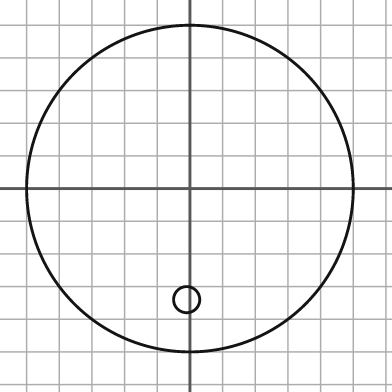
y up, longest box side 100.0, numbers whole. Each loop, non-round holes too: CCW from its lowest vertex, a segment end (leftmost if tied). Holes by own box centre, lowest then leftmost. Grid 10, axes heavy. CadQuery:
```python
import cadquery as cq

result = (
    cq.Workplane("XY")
    .moveTo(0.0, 0.0)
    .circle(50.0)
    .moveTo(-1.0, -34.0)
    .circle(4.0)
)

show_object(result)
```